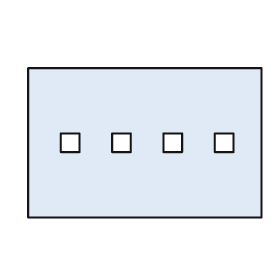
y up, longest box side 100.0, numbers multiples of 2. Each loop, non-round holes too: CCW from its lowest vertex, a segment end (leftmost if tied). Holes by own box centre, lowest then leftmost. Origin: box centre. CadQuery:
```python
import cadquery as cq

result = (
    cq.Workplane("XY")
    .moveTo(-50.0, -32.0)
    .lineTo(50.0, -32.0)
    .lineTo(50.0, 32.0)
    .lineTo(-50.0, 32.0)
    .close()
    .moveTo(-36.0, -4.0)
    .lineTo(-28.0, -4.0)
    .lineTo(-28.0, 4.0)
    .lineTo(-36.0, 4.0)
    .close()
    .moveTo(-14.0, -4.0)
    .lineTo(-6.0, -4.0)
    .lineTo(-6.0, 4.0)
    .lineTo(-14.0, 4.0)
    .close()
    .moveTo(8.0, -4.0)
    .lineTo(16.0, -4.0)
    .lineTo(16.0, 4.0)
    .lineTo(8.0, 4.0)
    .close()
    .moveTo(30.0, -4.0)
    .lineTo(38.0, -4.0)
    .lineTo(38.0, 4.0)
    .lineTo(30.0, 4.0)
    .close()
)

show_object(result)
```